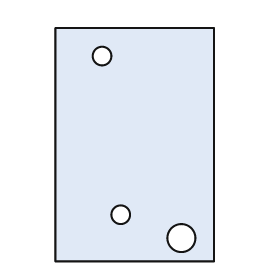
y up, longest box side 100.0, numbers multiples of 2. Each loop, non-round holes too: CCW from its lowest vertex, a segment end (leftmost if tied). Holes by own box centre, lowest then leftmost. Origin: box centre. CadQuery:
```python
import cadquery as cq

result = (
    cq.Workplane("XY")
    .moveTo(-34.0, -50.0)
    .lineTo(34.0, -50.0)
    .lineTo(34.0, 50.0)
    .lineTo(-34.0, 50.0)
    .close()
    .moveTo(20.0, -40.0)
    .circle(6.0)
    .moveTo(-6.0, -30.0)
    .circle(4.0)
    .moveTo(-14.0, 38.0)
    .circle(4.0)
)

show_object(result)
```